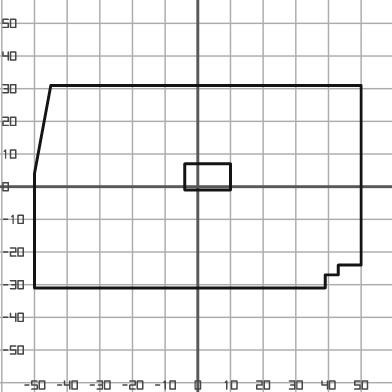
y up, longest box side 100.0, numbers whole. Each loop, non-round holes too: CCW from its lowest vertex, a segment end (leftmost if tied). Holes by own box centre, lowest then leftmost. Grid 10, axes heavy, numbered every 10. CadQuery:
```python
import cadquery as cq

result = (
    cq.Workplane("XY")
    .moveTo(-50.0, -31.0)
    .lineTo(39.0, -31.0)
    .lineTo(39.0, -27.0)
    .lineTo(43.0, -27.0)
    .lineTo(43.0, -24.0)
    .lineTo(50.0, -24.0)
    .lineTo(50.0, 31.0)
    .lineTo(-45.0, 31.0)
    .lineTo(-50.0, 4.0)
    .close()
    .moveTo(-4.0, -1.0)
    .lineTo(10.0, -1.0)
    .lineTo(10.0, 7.0)
    .lineTo(-4.0, 7.0)
    .close()
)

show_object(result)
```